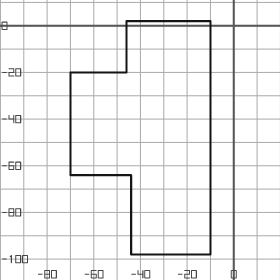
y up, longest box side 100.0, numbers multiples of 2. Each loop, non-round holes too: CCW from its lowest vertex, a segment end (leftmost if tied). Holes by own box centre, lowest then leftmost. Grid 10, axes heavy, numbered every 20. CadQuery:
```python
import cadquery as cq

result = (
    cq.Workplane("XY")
    .moveTo(-44.0, -98.0)
    .lineTo(-10.0, -98.0)
    .lineTo(-10.0, 2.0)
    .lineTo(-46.0, 2.0)
    .lineTo(-46.0, -20.0)
    .lineTo(-70.0, -20.0)
    .lineTo(-70.0, -64.0)
    .lineTo(-44.0, -64.0)
    .close()
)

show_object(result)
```